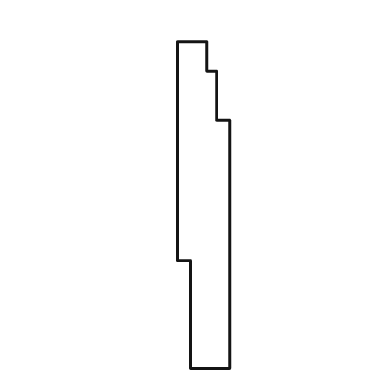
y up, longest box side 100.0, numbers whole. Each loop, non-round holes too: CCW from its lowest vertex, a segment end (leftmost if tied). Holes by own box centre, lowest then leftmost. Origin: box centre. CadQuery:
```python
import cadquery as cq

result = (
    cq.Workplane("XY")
    .moveTo(-4.0, -50.0)
    .lineTo(8.0, -50.0)
    .lineTo(8.0, 26.0)
    .lineTo(4.0, 26.0)
    .lineTo(4.0, 41.0)
    .lineTo(1.0, 41.0)
    .lineTo(1.0, 50.0)
    .lineTo(-8.0, 50.0)
    .lineTo(-8.0, -17.0)
    .lineTo(-4.0, -17.0)
    .close()
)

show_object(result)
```